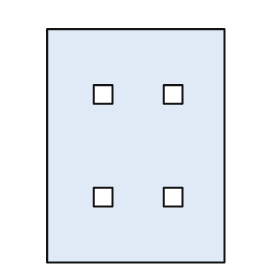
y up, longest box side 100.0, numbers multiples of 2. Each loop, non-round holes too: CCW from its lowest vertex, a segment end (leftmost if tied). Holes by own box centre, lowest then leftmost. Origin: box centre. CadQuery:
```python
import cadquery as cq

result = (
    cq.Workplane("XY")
    .moveTo(-38.0, -50.0)
    .lineTo(38.0, -50.0)
    .lineTo(38.0, 50.0)
    .lineTo(-38.0, 50.0)
    .close()
    .moveTo(-18.0, -26.0)
    .lineTo(-10.0, -26.0)
    .lineTo(-10.0, -18.0)
    .lineTo(-18.0, -18.0)
    .close()
    .moveTo(12.0, -26.0)
    .lineTo(20.0, -26.0)
    .lineTo(20.0, -18.0)
    .lineTo(12.0, -18.0)
    .close()
    .moveTo(-18.0, 18.0)
    .lineTo(-10.0, 18.0)
    .lineTo(-10.0, 26.0)
    .lineTo(-18.0, 26.0)
    .close()
    .moveTo(12.0, 18.0)
    .lineTo(20.0, 18.0)
    .lineTo(20.0, 26.0)
    .lineTo(12.0, 26.0)
    .close()
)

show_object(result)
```